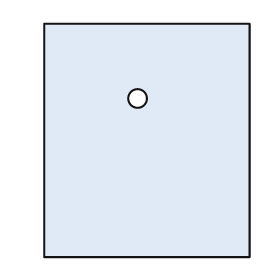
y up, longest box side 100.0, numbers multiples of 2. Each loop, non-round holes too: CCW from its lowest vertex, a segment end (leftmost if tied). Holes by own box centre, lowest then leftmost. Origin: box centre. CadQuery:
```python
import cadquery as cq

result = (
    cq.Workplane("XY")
    .moveTo(-44.0, -50.0)
    .lineTo(44.0, -50.0)
    .lineTo(44.0, 50.0)
    .lineTo(-44.0, 50.0)
    .close()
    .moveTo(-4.0, 18.0)
    .circle(4.0)
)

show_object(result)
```